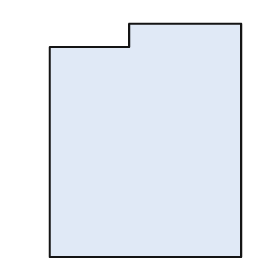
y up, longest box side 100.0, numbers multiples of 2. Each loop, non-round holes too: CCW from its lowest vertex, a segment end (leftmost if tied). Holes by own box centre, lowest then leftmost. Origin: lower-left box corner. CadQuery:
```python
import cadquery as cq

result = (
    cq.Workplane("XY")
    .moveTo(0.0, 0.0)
    .lineTo(82.0, 0.0)
    .lineTo(82.0, 100.0)
    .lineTo(34.0, 100.0)
    .lineTo(34.0, 90.0)
    .lineTo(0.0, 90.0)
    .close()
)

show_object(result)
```